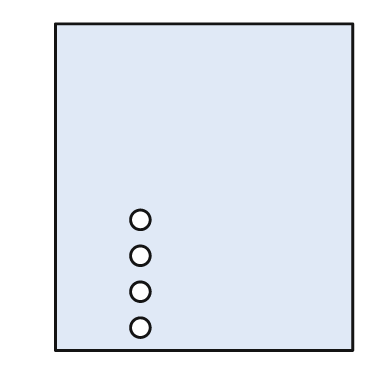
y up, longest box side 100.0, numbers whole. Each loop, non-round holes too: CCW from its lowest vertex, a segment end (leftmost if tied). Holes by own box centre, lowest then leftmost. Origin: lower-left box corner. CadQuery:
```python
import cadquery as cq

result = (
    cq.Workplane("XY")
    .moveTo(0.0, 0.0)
    .lineTo(91.0, 0.0)
    .lineTo(91.0, 100.0)
    .lineTo(0.0, 100.0)
    .close()
    .moveTo(26.0, 7.0)
    .circle(3.0)
    .moveTo(26.0, 18.0)
    .circle(3.0)
    .moveTo(26.0, 29.0)
    .circle(3.0)
    .moveTo(26.0, 40.0)
    .circle(3.0)
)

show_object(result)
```